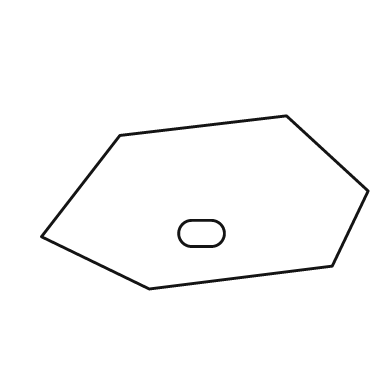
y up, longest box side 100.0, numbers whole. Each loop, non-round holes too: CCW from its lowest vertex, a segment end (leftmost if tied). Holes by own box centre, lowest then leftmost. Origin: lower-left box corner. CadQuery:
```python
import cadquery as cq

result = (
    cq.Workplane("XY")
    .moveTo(33.0, 0.0)
    .lineTo(89.0, 7.0)
    .lineTo(100.0, 30.0)
    .lineTo(75.0, 53.0)
    .lineTo(24.0, 47.0)
    .lineTo(0.0, 16.0)
    .close()
    .moveTo(46.0, 13.0)
    .lineTo(52.0, 13.0)
    .threePointArc((56.0, 17.0), (52.0, 21.0))
    .lineTo(46.0, 21.0)
    .threePointArc((42.0, 17.0), (46.0, 13.0))
    .close()
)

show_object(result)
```